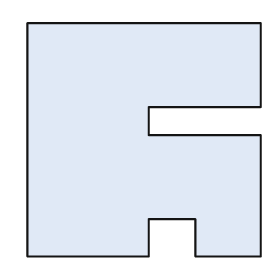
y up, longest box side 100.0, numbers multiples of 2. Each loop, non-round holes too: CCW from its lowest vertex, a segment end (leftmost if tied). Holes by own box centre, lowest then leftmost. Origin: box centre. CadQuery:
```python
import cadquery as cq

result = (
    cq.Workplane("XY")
    .moveTo(-50.0, -50.0)
    .lineTo(2.0, -50.0)
    .lineTo(2.0, -34.0)
    .lineTo(22.0, -34.0)
    .lineTo(22.0, -50.0)
    .lineTo(50.0, -50.0)
    .lineTo(50.0, 2.0)
    .lineTo(2.0, 2.0)
    .lineTo(2.0, 14.0)
    .lineTo(50.0, 14.0)
    .lineTo(50.0, 50.0)
    .lineTo(-50.0, 50.0)
    .close()
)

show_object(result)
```